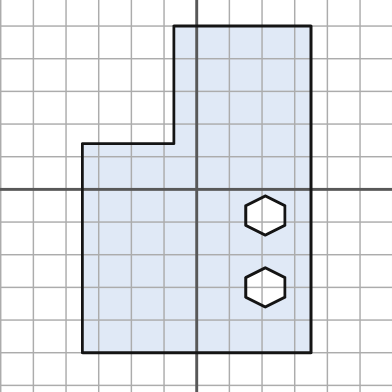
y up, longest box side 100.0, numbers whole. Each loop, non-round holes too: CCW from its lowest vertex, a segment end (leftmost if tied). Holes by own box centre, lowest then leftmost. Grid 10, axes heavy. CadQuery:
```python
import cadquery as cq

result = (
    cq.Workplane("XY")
    .moveTo(-35.0, -50.0)
    .lineTo(35.0, -50.0)
    .lineTo(35.0, 50.0)
    .lineTo(-7.0, 50.0)
    .lineTo(-7.0, 14.0)
    .lineTo(-35.0, 14.0)
    .close()
    .moveTo(21.0, -36.0)
    .lineTo(27.0, -33.0)
    .lineTo(27.0, -27.0)
    .lineTo(21.0, -24.0)
    .lineTo(15.0, -27.0)
    .lineTo(15.0, -33.0)
    .close()
    .moveTo(21.0, -14.0)
    .lineTo(27.0, -11.0)
    .lineTo(27.0, -5.0)
    .lineTo(21.0, -2.0)
    .lineTo(15.0, -5.0)
    .lineTo(15.0, -11.0)
    .close()
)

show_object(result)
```